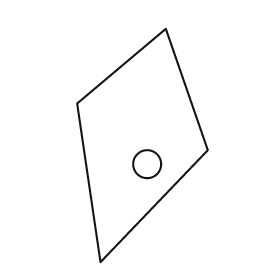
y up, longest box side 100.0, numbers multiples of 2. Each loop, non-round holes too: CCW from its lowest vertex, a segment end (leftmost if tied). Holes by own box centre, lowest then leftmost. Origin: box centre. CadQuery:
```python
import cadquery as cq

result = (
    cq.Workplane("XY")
    .moveTo(-18.0, -50.0)
    .lineTo(28.0, -2.0)
    .lineTo(10.0, 50.0)
    .lineTo(-28.0, 18.0)
    .close()
    .moveTo(2.0, -8.0)
    .circle(6.0)
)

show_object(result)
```